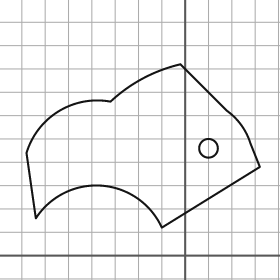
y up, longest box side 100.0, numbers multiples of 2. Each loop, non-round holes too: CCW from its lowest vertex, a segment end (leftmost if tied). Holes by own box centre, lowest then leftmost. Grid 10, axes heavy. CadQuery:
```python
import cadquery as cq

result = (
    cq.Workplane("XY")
    .moveTo(-10.0, 12.0)
    .lineTo(32.0, 38.0)
    .lineTo(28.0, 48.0)
    .threePointArc((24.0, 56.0), (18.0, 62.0))
    .lineTo(-2.0, 82.0)
    .threePointArc((-18.0, 76.0), (-32.0, 66.0))
    .threePointArc((-54.0, 62.0), (-68.0, 44.0))
    .lineTo(-64.0, 16.0)
    .threePointArc((-36.0, 30.0), (-10.0, 12.0))
    .close()
    .moveTo(10.0, 46.0)
    .circle(4.0)
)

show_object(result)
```